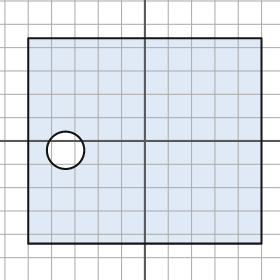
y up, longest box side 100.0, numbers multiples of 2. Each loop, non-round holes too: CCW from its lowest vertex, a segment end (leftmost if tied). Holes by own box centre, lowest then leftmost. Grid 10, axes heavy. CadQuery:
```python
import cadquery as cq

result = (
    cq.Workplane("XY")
    .moveTo(-50.0, -44.0)
    .lineTo(50.0, -44.0)
    .lineTo(50.0, 44.0)
    .lineTo(-50.0, 44.0)
    .close()
    .moveTo(-34.0, -4.0)
    .circle(8.0)
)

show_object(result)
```